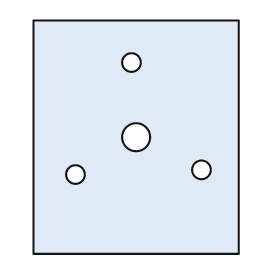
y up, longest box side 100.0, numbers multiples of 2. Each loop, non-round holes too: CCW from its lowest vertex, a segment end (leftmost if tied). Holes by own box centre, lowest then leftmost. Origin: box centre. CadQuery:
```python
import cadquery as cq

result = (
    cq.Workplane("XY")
    .moveTo(-44.0, -50.0)
    .lineTo(44.0, -50.0)
    .lineTo(44.0, 50.0)
    .lineTo(-44.0, 50.0)
    .close()
    .moveTo(-26.0, -16.0)
    .circle(4.0)
    .moveTo(28.0, -14.0)
    .circle(4.0)
    .moveTo(0.0, 0.0)
    .circle(6.0)
    .moveTo(-2.0, 32.0)
    .circle(4.0)
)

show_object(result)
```